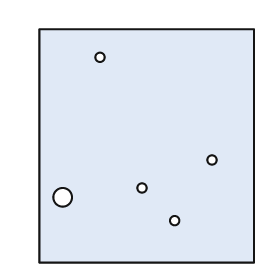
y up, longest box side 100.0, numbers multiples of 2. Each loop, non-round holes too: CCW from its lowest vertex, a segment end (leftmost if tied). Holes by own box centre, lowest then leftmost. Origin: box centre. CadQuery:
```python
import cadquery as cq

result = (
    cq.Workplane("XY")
    .moveTo(-46.0, -50.0)
    .lineTo(46.0, -50.0)
    .lineTo(46.0, 50.0)
    .lineTo(-46.0, 50.0)
    .close()
    .moveTo(12.0, -32.0)
    .circle(2.0)
    .moveTo(-36.0, -22.0)
    .circle(4.0)
    .moveTo(-2.0, -18.0)
    .circle(2.0)
    .moveTo(28.0, -6.0)
    .circle(2.0)
    .moveTo(-20.0, 38.0)
    .circle(2.0)
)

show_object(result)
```